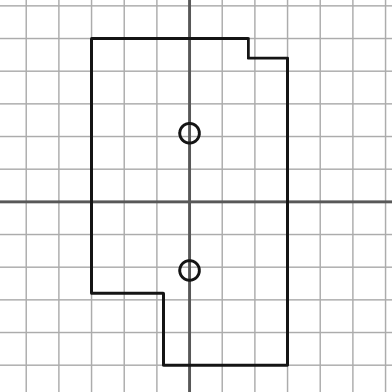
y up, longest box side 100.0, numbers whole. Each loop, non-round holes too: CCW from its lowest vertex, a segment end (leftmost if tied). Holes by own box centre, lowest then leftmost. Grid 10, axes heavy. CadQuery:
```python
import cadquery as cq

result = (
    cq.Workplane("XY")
    .moveTo(-8.0, -50.0)
    .lineTo(30.0, -50.0)
    .lineTo(30.0, 44.0)
    .lineTo(18.0, 44.0)
    .lineTo(18.0, 50.0)
    .lineTo(-30.0, 50.0)
    .lineTo(-30.0, -28.0)
    .lineTo(-8.0, -28.0)
    .close()
    .moveTo(0.0, -21.0)
    .circle(3.0)
    .moveTo(0.0, 21.0)
    .circle(3.0)
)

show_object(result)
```